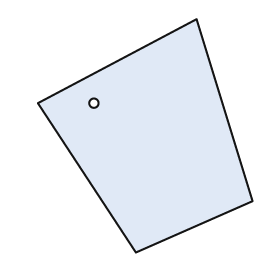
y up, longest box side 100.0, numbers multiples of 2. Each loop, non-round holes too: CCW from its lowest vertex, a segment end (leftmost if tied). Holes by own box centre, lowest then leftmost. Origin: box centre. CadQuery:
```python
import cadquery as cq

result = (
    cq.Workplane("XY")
    .moveTo(-4.0, -50.0)
    .lineTo(46.0, -28.0)
    .lineTo(22.0, 50.0)
    .lineTo(-46.0, 14.0)
    .close()
    .moveTo(-22.0, 14.0)
    .circle(2.0)
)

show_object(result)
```